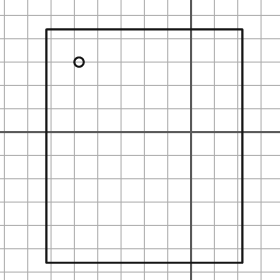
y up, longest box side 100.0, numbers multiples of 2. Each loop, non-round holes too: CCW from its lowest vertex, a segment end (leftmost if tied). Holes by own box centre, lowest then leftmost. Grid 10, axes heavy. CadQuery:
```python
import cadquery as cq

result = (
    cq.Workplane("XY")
    .moveTo(-62.0, -56.0)
    .lineTo(22.0, -56.0)
    .lineTo(22.0, 44.0)
    .lineTo(-62.0, 44.0)
    .close()
    .moveTo(-48.0, 30.0)
    .circle(2.0)
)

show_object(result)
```